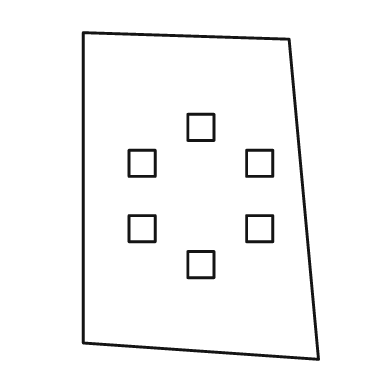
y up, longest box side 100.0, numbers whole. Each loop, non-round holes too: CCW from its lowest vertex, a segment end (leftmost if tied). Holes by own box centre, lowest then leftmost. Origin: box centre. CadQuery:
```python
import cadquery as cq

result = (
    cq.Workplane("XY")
    .moveTo(36.0, -50.0)
    .lineTo(27.0, 48.0)
    .lineTo(-36.0, 50.0)
    .lineTo(-36.0, -45.0)
    .close()
    .moveTo(-4.0, -25.0)
    .lineTo(4.0, -25.0)
    .lineTo(4.0, -17.0)
    .lineTo(-4.0, -17.0)
    .close()
    .moveTo(-22.0, -14.0)
    .lineTo(-14.0, -14.0)
    .lineTo(-14.0, -6.0)
    .lineTo(-22.0, -6.0)
    .close()
    .moveTo(14.0, -14.0)
    .lineTo(22.0, -14.0)
    .lineTo(22.0, -6.0)
    .lineTo(14.0, -6.0)
    .close()
    .moveTo(-22.0, 6.0)
    .lineTo(-14.0, 6.0)
    .lineTo(-14.0, 14.0)
    .lineTo(-22.0, 14.0)
    .close()
    .moveTo(14.0, 6.0)
    .lineTo(22.0, 6.0)
    .lineTo(22.0, 14.0)
    .lineTo(14.0, 14.0)
    .close()
    .moveTo(-4.0, 17.0)
    .lineTo(4.0, 17.0)
    .lineTo(4.0, 25.0)
    .lineTo(-4.0, 25.0)
    .close()
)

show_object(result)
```